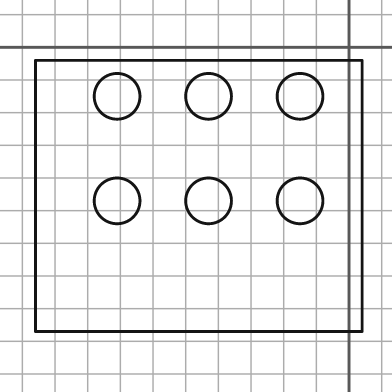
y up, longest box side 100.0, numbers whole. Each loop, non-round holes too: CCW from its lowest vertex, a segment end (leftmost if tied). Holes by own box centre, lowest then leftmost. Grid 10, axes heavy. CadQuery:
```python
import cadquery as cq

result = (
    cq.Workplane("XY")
    .moveTo(-96.0, -87.0)
    .lineTo(4.0, -87.0)
    .lineTo(4.0, -4.0)
    .lineTo(-96.0, -4.0)
    .close()
    .moveTo(-71.0, -47.0)
    .circle(7.0)
    .moveTo(-43.0, -47.0)
    .circle(7.0)
    .moveTo(-15.0, -47.0)
    .circle(7.0)
    .moveTo(-71.0, -15.0)
    .circle(7.0)
    .moveTo(-43.0, -15.0)
    .circle(7.0)
    .moveTo(-15.0, -15.0)
    .circle(7.0)
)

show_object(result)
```